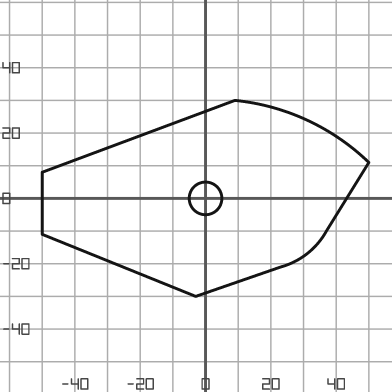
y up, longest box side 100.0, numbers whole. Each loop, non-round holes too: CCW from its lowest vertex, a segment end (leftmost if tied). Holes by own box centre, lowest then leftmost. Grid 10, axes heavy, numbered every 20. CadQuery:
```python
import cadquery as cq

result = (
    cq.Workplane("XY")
    .moveTo(-3.0, -30.0)
    .lineTo(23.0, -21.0)
    .threePointArc((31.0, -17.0), (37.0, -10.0))
    .lineTo(50.0, 11.0)
    .threePointArc((31.0, 24.0), (9.0, 30.0))
    .lineTo(-50.0, 8.0)
    .lineTo(-50.0, -11.0)
    .close()
    .moveTo(0.0, 0.0)
    .circle(5.0)
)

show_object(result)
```